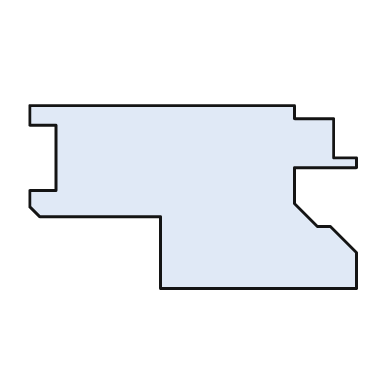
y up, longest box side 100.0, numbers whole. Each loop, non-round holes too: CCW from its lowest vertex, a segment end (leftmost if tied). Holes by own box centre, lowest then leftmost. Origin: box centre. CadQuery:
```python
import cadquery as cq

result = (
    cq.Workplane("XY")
    .moveTo(-10.0, -28.0)
    .lineTo(50.0, -28.0)
    .lineTo(50.0, -17.0)
    .lineTo(42.0, -9.0)
    .lineTo(38.0, -9.0)
    .lineTo(31.0, -2.0)
    .lineTo(31.0, 9.0)
    .lineTo(50.0, 9.0)
    .lineTo(50.0, 12.0)
    .lineTo(43.0, 12.0)
    .lineTo(43.0, 24.0)
    .lineTo(31.0, 24.0)
    .lineTo(31.0, 28.0)
    .lineTo(-50.0, 28.0)
    .lineTo(-50.0, 22.0)
    .lineTo(-42.0, 22.0)
    .lineTo(-42.0, 2.0)
    .lineTo(-50.0, 2.0)
    .lineTo(-50.0, -3.0)
    .lineTo(-47.0, -6.0)
    .lineTo(-10.0, -6.0)
    .close()
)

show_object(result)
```